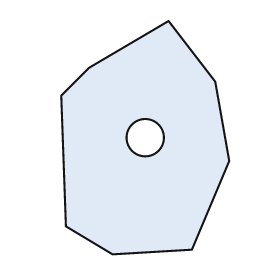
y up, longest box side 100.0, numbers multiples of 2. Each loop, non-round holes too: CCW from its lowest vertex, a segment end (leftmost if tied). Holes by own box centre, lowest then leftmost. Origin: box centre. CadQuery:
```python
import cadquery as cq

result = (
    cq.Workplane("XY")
    .moveTo(-14.0, -50.0)
    .lineTo(20.0, -48.0)
    .lineTo(36.0, -10.0)
    .lineTo(30.0, 24.0)
    .lineTo(10.0, 50.0)
    .lineTo(-24.0, 30.0)
    .lineTo(-36.0, 18.0)
    .lineTo(-34.0, -38.0)
    .close()
    .moveTo(0.0, 0.0)
    .circle(8.0)
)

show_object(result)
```